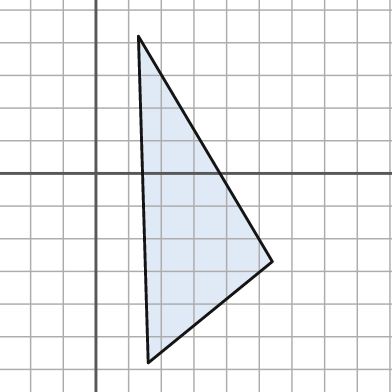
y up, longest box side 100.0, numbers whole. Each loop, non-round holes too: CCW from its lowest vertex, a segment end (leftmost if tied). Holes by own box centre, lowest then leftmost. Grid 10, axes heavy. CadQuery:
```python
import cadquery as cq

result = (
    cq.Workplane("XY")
    .moveTo(16.0, -58.0)
    .lineTo(54.0, -27.0)
    .lineTo(13.0, 42.0)
    .close()
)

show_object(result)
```